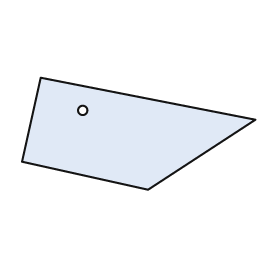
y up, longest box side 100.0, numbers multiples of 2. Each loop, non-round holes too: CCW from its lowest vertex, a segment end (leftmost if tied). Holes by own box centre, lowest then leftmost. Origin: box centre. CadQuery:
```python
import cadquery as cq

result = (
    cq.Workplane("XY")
    .moveTo(4.0, -24.0)
    .lineTo(50.0, 6.0)
    .lineTo(-42.0, 24.0)
    .lineTo(-50.0, -12.0)
    .close()
    .moveTo(-24.0, 10.0)
    .circle(2.0)
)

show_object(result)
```